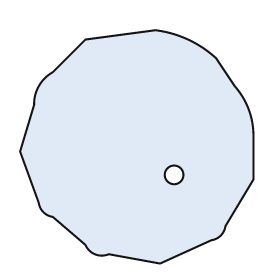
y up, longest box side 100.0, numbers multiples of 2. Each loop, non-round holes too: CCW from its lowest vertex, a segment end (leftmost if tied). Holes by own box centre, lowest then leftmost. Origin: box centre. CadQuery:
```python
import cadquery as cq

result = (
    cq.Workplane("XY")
    .moveTo(10.0, -50.0)
    .lineTo(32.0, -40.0)
    .threePointArc((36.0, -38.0), (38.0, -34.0))
    .lineTo(50.0, -14.0)
    .lineTo(50.0, 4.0)
    .threePointArc((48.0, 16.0), (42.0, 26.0))
    .lineTo(34.0, 38.0)
    .threePointArc((22.0, 46.0), (8.0, 50.0))
    .lineTo(-22.0, 46.0)
    .lineTo(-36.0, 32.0)
    .threePointArc((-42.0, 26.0), (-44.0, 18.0))
    .lineTo(-50.0, -2.0)
    .lineTo(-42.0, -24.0)
    .threePointArc((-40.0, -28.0), (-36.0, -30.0))
    .lineTo(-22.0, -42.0)
    .threePointArc((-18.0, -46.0), (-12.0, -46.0))
    .close()
    .moveTo(16.0, -12.0)
    .circle(4.0)
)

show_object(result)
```